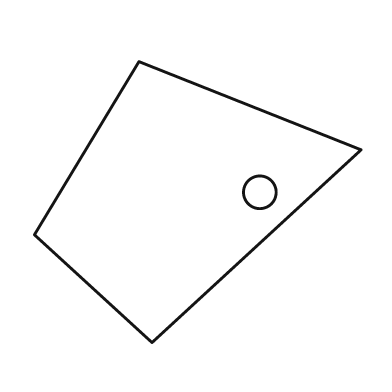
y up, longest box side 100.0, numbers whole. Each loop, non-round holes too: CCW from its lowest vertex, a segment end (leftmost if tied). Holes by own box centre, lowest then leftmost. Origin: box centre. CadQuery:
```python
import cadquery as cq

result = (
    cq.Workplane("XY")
    .moveTo(-14.0, -43.0)
    .lineTo(50.0, 16.0)
    .lineTo(-18.0, 43.0)
    .lineTo(-50.0, -10.0)
    .close()
    .moveTo(19.0, 3.0)
    .circle(5.0)
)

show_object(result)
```